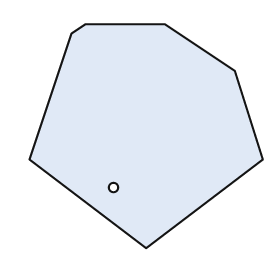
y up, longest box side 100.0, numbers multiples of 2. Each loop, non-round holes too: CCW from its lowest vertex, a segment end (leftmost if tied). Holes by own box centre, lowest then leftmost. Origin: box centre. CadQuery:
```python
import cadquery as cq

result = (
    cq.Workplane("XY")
    .moveTo(0.0, -48.0)
    .lineTo(50.0, -10.0)
    .lineTo(38.0, 28.0)
    .lineTo(8.0, 48.0)
    .lineTo(-26.0, 48.0)
    .lineTo(-32.0, 44.0)
    .lineTo(-50.0, -10.0)
    .close()
    .moveTo(-14.0, -22.0)
    .circle(2.0)
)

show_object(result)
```